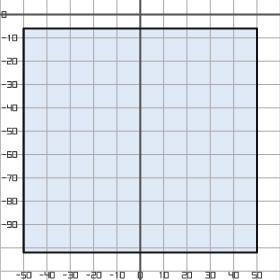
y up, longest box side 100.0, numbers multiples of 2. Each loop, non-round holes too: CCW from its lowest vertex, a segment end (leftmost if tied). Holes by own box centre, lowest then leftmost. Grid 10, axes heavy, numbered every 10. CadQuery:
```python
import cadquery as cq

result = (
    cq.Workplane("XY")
    .moveTo(-50.0, -102.0)
    .lineTo(50.0, -102.0)
    .lineTo(50.0, -6.0)
    .lineTo(-50.0, -6.0)
    .close()
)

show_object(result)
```